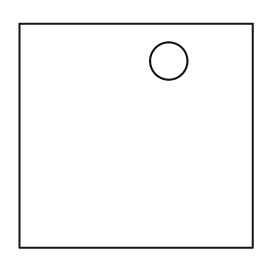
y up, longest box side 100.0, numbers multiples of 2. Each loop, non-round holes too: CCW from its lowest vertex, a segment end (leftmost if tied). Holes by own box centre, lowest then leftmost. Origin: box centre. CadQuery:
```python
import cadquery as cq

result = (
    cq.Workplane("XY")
    .moveTo(-50.0, -48.0)
    .lineTo(50.0, -48.0)
    .lineTo(50.0, 48.0)
    .lineTo(-50.0, 48.0)
    .close()
    .moveTo(14.0, 32.0)
    .circle(8.0)
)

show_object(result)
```